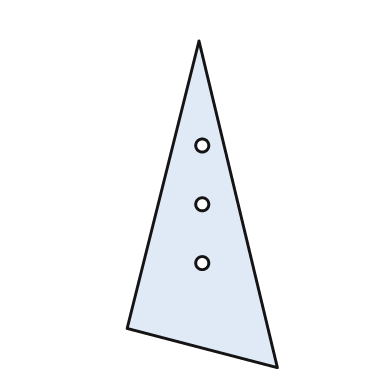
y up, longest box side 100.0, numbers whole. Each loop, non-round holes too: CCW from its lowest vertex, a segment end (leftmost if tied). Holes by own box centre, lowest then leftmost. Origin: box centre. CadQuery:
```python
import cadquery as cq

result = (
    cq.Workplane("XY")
    .moveTo(23.0, -50.0)
    .lineTo(-1.0, 50.0)
    .lineTo(-23.0, -38.0)
    .close()
    .moveTo(0.0, -18.0)
    .circle(2.0)
    .moveTo(0.0, 0.0)
    .circle(2.0)
    .moveTo(0.0, 18.0)
    .circle(2.0)
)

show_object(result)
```